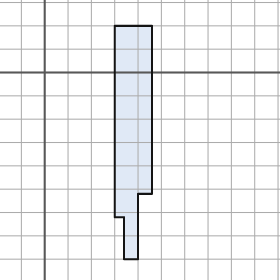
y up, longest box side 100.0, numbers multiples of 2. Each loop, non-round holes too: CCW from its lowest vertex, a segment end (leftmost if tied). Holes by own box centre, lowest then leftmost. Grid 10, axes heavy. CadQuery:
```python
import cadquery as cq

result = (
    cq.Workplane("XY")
    .moveTo(34.0, -80.0)
    .lineTo(40.0, -80.0)
    .lineTo(40.0, -52.0)
    .lineTo(46.0, -52.0)
    .lineTo(46.0, 20.0)
    .lineTo(30.0, 20.0)
    .lineTo(30.0, -62.0)
    .lineTo(34.0, -62.0)
    .close()
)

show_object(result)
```